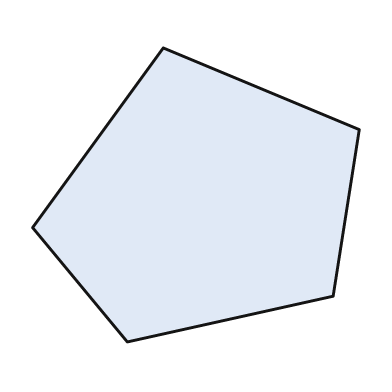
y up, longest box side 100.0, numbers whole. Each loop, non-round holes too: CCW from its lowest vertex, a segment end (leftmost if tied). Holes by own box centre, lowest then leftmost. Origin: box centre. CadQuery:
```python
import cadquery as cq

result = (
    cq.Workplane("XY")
    .moveTo(-21.0, -45.0)
    .lineTo(42.0, -31.0)
    .lineTo(50.0, 20.0)
    .lineTo(-10.0, 45.0)
    .lineTo(-50.0, -10.0)
    .close()
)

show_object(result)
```